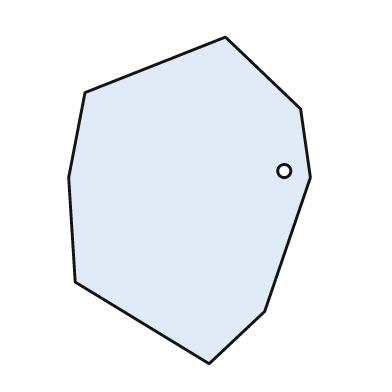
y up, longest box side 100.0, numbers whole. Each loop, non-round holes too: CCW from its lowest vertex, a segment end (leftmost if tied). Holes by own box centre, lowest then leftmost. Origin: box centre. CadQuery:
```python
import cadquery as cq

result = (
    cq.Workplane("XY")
    .moveTo(6.0, -50.0)
    .lineTo(23.0, -34.0)
    .lineTo(37.0, 7.0)
    .lineTo(34.0, 28.0)
    .lineTo(11.0, 50.0)
    .lineTo(-32.0, 33.0)
    .lineTo(-37.0, 7.0)
    .lineTo(-35.0, -25.0)
    .close()
    .moveTo(29.0, 9.0)
    .circle(2.0)
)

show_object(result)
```